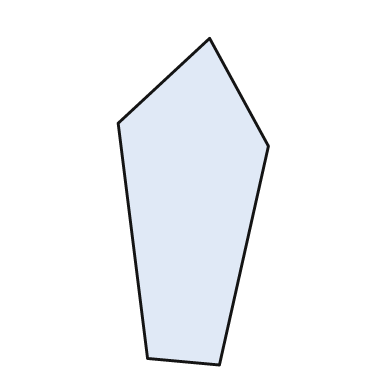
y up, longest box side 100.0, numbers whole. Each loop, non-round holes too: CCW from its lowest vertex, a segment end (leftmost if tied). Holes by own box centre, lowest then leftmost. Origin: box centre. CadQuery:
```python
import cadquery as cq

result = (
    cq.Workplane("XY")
    .moveTo(8.0, -50.0)
    .lineTo(23.0, 17.0)
    .lineTo(5.0, 50.0)
    .lineTo(-23.0, 24.0)
    .lineTo(-14.0, -48.0)
    .close()
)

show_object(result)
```